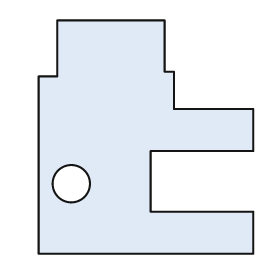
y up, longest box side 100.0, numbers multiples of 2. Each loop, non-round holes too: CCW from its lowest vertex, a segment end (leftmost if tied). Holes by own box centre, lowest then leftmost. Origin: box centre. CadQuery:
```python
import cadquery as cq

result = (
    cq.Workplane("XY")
    .moveTo(-46.0, -50.0)
    .lineTo(46.0, -50.0)
    .lineTo(46.0, -32.0)
    .lineTo(2.0, -32.0)
    .lineTo(2.0, -6.0)
    .lineTo(46.0, -6.0)
    .lineTo(46.0, 12.0)
    .lineTo(12.0, 12.0)
    .lineTo(12.0, 28.0)
    .lineTo(8.0, 28.0)
    .lineTo(8.0, 50.0)
    .lineTo(-38.0, 50.0)
    .lineTo(-38.0, 26.0)
    .lineTo(-46.0, 26.0)
    .close()
    .moveTo(-32.0, -20.0)
    .circle(8.0)
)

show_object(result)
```